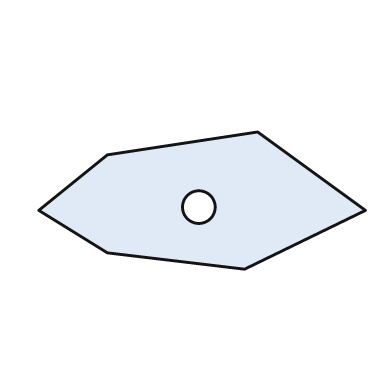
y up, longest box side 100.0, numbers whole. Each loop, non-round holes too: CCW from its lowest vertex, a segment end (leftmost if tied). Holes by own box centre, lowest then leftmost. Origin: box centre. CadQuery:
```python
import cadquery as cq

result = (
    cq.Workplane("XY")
    .moveTo(13.0, -21.0)
    .lineTo(50.0, -3.0)
    .lineTo(17.0, 21.0)
    .lineTo(-29.0, 14.0)
    .lineTo(-50.0, -3.0)
    .lineTo(-29.0, -16.0)
    .close()
    .moveTo(-1.0, -2.0)
    .circle(5.0)
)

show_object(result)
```